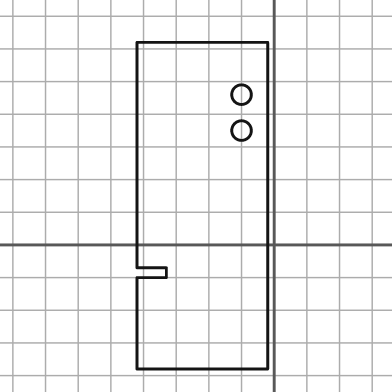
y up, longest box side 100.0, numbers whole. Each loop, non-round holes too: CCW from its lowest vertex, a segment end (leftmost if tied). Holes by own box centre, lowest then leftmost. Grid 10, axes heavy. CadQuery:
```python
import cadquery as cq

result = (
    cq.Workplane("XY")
    .moveTo(-42.0, -38.0)
    .lineTo(-2.0, -38.0)
    .lineTo(-2.0, 62.0)
    .lineTo(-42.0, 62.0)
    .lineTo(-42.0, -7.0)
    .lineTo(-33.0, -7.0)
    .lineTo(-33.0, -10.0)
    .lineTo(-42.0, -10.0)
    .close()
    .moveTo(-10.0, 35.0)
    .circle(3.0)
    .moveTo(-10.0, 46.0)
    .circle(3.0)
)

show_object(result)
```